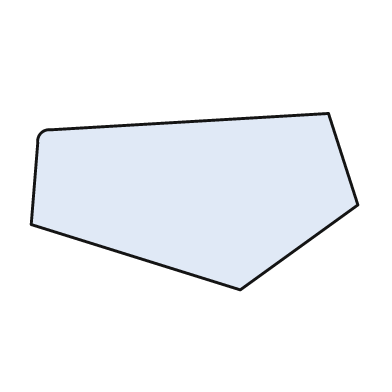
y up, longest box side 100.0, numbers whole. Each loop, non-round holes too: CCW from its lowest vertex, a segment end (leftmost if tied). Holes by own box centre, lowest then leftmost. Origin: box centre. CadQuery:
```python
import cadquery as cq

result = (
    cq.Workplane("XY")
    .moveTo(14.0, -27.0)
    .lineTo(50.0, -1.0)
    .lineTo(41.0, 27.0)
    .lineTo(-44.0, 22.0)
    .threePointArc((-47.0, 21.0), (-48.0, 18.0))
    .lineTo(-50.0, -7.0)
    .close()
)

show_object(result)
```